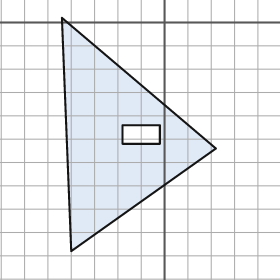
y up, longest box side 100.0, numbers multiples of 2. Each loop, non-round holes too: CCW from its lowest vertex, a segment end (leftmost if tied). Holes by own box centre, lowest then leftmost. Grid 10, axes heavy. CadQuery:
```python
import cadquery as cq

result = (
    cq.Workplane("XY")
    .moveTo(-40.0, -98.0)
    .lineTo(22.0, -54.0)
    .lineTo(-44.0, 2.0)
    .close()
    .moveTo(-18.0, -52.0)
    .lineTo(-2.0, -52.0)
    .lineTo(-2.0, -44.0)
    .lineTo(-18.0, -44.0)
    .close()
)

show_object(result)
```